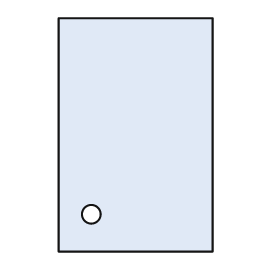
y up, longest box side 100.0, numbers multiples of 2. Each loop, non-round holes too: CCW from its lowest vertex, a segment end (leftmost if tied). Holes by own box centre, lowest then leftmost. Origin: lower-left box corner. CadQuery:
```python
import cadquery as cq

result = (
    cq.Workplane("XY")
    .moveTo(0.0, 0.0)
    .lineTo(66.0, 0.0)
    .lineTo(66.0, 100.0)
    .lineTo(0.0, 100.0)
    .close()
    .moveTo(14.0, 16.0)
    .circle(4.0)
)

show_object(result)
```